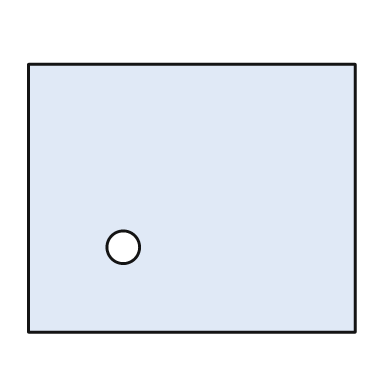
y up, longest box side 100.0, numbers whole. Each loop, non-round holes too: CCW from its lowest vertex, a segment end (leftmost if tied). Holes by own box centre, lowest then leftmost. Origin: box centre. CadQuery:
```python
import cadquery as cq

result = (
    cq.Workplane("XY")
    .moveTo(-50.0, -41.0)
    .lineTo(50.0, -41.0)
    .lineTo(50.0, 41.0)
    .lineTo(-50.0, 41.0)
    .close()
    .moveTo(-21.0, -15.0)
    .circle(5.0)
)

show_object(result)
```